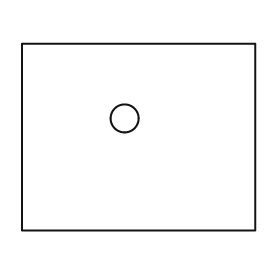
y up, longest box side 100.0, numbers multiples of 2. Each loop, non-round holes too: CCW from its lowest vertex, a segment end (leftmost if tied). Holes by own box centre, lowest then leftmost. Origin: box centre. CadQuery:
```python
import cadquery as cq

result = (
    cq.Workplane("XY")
    .moveTo(-50.0, -40.0)
    .lineTo(50.0, -40.0)
    .lineTo(50.0, 40.0)
    .lineTo(-50.0, 40.0)
    .close()
    .moveTo(-6.0, 8.0)
    .circle(6.0)
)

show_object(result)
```